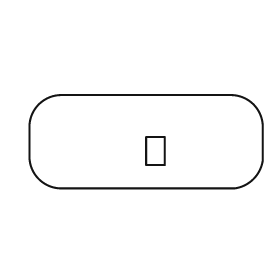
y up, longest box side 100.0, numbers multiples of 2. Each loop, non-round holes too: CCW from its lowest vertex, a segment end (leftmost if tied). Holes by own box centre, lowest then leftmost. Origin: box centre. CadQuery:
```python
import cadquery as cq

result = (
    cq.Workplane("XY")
    .moveTo(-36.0, -20.0)
    .lineTo(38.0, -20.0)
    .threePointArc((46.0, -16.0), (50.0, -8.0))
    .lineTo(50.0, 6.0)
    .threePointArc((46.0, 16.0), (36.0, 20.0))
    .lineTo(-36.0, 20.0)
    .threePointArc((-46.0, 16.0), (-50.0, 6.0))
    .lineTo(-50.0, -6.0)
    .threePointArc((-46.0, -16.0), (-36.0, -20.0))
    .close()
    .moveTo(0.0, -10.0)
    .lineTo(8.0, -10.0)
    .lineTo(8.0, 2.0)
    .lineTo(0.0, 2.0)
    .close()
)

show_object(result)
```